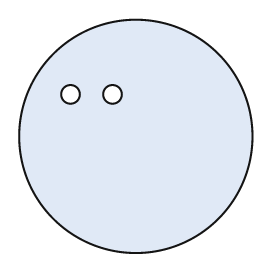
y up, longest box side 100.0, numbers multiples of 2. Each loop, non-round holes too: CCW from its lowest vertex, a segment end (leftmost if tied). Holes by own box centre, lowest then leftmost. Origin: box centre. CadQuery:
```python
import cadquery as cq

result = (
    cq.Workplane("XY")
    .moveTo(0.0, 0.0)
    .circle(50.0)
    .moveTo(-28.0, 18.0)
    .circle(4.0)
    .moveTo(-10.0, 18.0)
    .circle(4.0)
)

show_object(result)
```